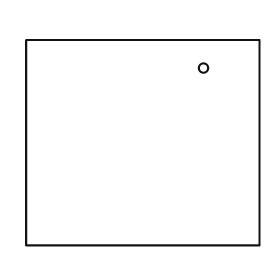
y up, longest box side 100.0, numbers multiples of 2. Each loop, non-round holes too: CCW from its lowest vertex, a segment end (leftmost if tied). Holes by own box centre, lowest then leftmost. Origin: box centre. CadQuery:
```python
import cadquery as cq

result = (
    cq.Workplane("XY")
    .moveTo(-50.0, -44.0)
    .lineTo(50.0, -44.0)
    .lineTo(50.0, 44.0)
    .lineTo(-50.0, 44.0)
    .close()
    .moveTo(26.0, 32.0)
    .circle(2.0)
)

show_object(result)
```